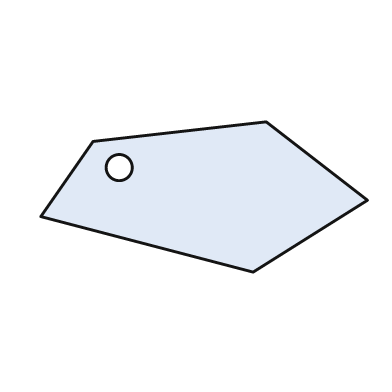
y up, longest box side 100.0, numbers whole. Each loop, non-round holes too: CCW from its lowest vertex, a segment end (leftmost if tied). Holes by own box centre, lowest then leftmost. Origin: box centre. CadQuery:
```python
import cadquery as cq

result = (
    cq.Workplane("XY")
    .moveTo(15.0, -23.0)
    .lineTo(50.0, -1.0)
    .lineTo(19.0, 23.0)
    .lineTo(-34.0, 17.0)
    .lineTo(-50.0, -6.0)
    .close()
    .moveTo(-26.0, 9.0)
    .circle(4.0)
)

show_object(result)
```